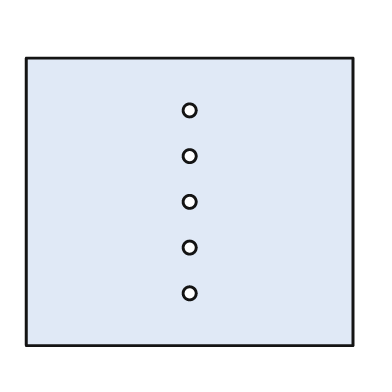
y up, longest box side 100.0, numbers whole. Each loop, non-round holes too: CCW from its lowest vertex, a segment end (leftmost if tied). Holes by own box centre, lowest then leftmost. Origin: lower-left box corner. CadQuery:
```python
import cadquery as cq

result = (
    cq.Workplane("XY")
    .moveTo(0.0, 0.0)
    .lineTo(100.0, 0.0)
    .lineTo(100.0, 88.0)
    .lineTo(0.0, 88.0)
    .close()
    .moveTo(50.0, 16.0)
    .circle(2.0)
    .moveTo(50.0, 30.0)
    .circle(2.0)
    .moveTo(50.0, 44.0)
    .circle(2.0)
    .moveTo(50.0, 58.0)
    .circle(2.0)
    .moveTo(50.0, 72.0)
    .circle(2.0)
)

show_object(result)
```